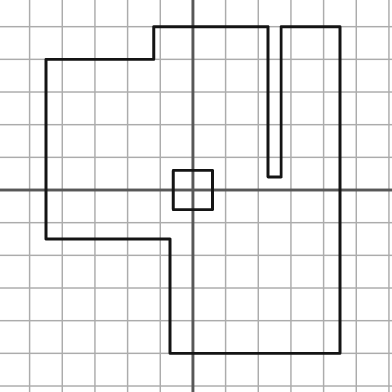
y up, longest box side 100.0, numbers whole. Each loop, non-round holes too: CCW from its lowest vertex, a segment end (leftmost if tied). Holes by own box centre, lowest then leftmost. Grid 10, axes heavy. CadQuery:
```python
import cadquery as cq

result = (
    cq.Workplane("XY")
    .moveTo(-7.0, -50.0)
    .lineTo(45.0, -50.0)
    .lineTo(45.0, 50.0)
    .lineTo(27.0, 50.0)
    .lineTo(27.0, 4.0)
    .lineTo(23.0, 4.0)
    .lineTo(23.0, 50.0)
    .lineTo(-12.0, 50.0)
    .lineTo(-12.0, 40.0)
    .lineTo(-45.0, 40.0)
    .lineTo(-45.0, -15.0)
    .lineTo(-7.0, -15.0)
    .close()
    .moveTo(-6.0, -6.0)
    .lineTo(6.0, -6.0)
    .lineTo(6.0, 6.0)
    .lineTo(-6.0, 6.0)
    .close()
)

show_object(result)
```